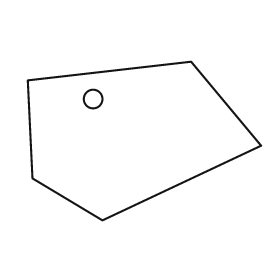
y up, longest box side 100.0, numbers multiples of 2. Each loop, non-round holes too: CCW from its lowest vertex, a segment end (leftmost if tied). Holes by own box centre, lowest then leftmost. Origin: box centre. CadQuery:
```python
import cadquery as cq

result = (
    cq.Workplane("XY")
    .moveTo(-18.0, -34.0)
    .lineTo(50.0, -2.0)
    .lineTo(20.0, 34.0)
    .lineTo(-50.0, 26.0)
    .lineTo(-48.0, -16.0)
    .close()
    .moveTo(-22.0, 18.0)
    .circle(4.0)
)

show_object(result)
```